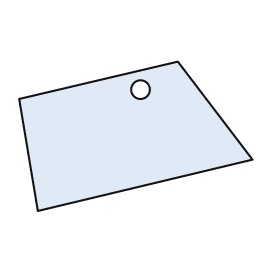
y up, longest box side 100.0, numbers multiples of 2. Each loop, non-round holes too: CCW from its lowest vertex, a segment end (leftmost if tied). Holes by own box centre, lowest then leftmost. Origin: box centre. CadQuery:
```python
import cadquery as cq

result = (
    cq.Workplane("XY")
    .moveTo(-42.0, -32.0)
    .lineTo(50.0, -10.0)
    .lineTo(18.0, 32.0)
    .lineTo(-50.0, 16.0)
    .close()
    .moveTo(2.0, 20.0)
    .circle(4.0)
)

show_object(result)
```